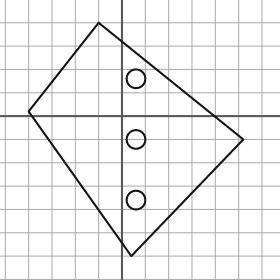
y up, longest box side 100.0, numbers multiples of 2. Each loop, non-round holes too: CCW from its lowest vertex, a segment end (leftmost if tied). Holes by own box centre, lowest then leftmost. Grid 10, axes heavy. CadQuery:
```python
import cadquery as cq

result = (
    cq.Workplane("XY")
    .moveTo(4.0, -60.0)
    .lineTo(52.0, -10.0)
    .lineTo(-10.0, 40.0)
    .lineTo(-40.0, 2.0)
    .close()
    .moveTo(6.0, -36.0)
    .circle(4.0)
    .moveTo(6.0, -10.0)
    .circle(4.0)
    .moveTo(6.0, 16.0)
    .circle(4.0)
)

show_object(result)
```